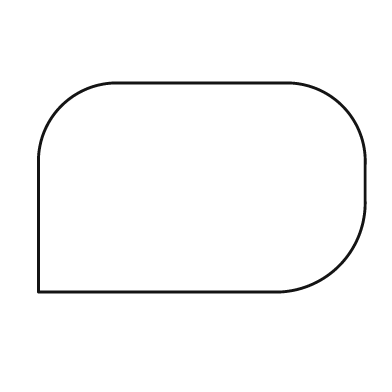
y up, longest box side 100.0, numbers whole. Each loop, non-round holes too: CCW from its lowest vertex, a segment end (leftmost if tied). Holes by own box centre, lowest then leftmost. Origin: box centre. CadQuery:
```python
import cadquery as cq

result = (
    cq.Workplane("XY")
    .moveTo(-50.0, -32.0)
    .lineTo(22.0, -32.0)
    .threePointArc((42.0, -24.0), (50.0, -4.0))
    .lineTo(50.0, 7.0)
    .threePointArc((43.0, 25.0), (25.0, 32.0))
    .lineTo(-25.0, 32.0)
    .threePointArc((-43.0, 25.0), (-50.0, 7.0))
    .close()
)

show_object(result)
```